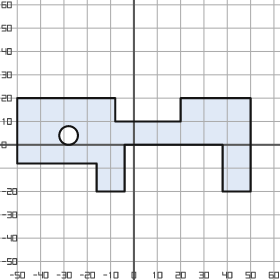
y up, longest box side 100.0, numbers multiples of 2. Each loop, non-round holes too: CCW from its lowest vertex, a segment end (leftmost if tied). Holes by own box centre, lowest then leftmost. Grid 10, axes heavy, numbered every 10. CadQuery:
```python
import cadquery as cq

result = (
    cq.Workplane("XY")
    .moveTo(-16.0, -20.0)
    .lineTo(-4.0, -20.0)
    .lineTo(-4.0, 0.0)
    .lineTo(38.0, 0.0)
    .lineTo(38.0, -20.0)
    .lineTo(50.0, -20.0)
    .lineTo(50.0, 20.0)
    .lineTo(20.0, 20.0)
    .lineTo(20.0, 10.0)
    .lineTo(-8.0, 10.0)
    .lineTo(-8.0, 20.0)
    .lineTo(-50.0, 20.0)
    .lineTo(-50.0, -8.0)
    .lineTo(-16.0, -8.0)
    .close()
    .moveTo(-28.0, 4.0)
    .circle(4.0)
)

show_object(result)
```